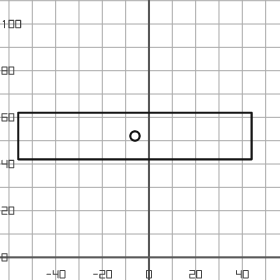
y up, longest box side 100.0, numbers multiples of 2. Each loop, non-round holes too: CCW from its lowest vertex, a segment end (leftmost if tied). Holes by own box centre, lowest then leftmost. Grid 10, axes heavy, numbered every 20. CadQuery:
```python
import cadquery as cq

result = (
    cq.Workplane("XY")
    .moveTo(-56.0, 42.0)
    .lineTo(44.0, 42.0)
    .lineTo(44.0, 62.0)
    .lineTo(-56.0, 62.0)
    .close()
    .moveTo(-6.0, 52.0)
    .circle(2.0)
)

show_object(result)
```